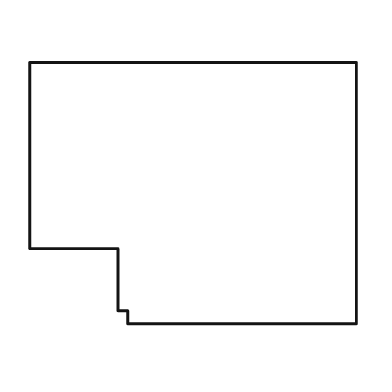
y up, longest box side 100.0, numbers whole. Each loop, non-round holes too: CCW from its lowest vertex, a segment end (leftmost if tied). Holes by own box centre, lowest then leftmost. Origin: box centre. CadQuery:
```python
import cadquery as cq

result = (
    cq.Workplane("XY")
    .moveTo(-20.0, -40.0)
    .lineTo(50.0, -40.0)
    .lineTo(50.0, 40.0)
    .lineTo(-50.0, 40.0)
    .lineTo(-50.0, -17.0)
    .lineTo(-23.0, -17.0)
    .lineTo(-23.0, -36.0)
    .lineTo(-20.0, -36.0)
    .close()
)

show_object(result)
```